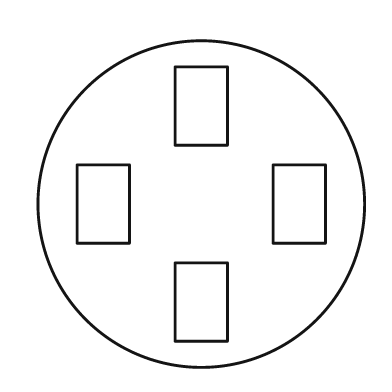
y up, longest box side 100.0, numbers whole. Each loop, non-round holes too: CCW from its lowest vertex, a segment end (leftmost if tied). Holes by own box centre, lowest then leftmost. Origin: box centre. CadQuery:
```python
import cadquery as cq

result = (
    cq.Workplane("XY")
    .moveTo(0.0, 0.0)
    .circle(50.0)
    .moveTo(-8.0, -42.0)
    .lineTo(8.0, -42.0)
    .lineTo(8.0, -18.0)
    .lineTo(-8.0, -18.0)
    .close()
    .moveTo(-38.0, -12.0)
    .lineTo(-22.0, -12.0)
    .lineTo(-22.0, 12.0)
    .lineTo(-38.0, 12.0)
    .close()
    .moveTo(22.0, -12.0)
    .lineTo(38.0, -12.0)
    .lineTo(38.0, 12.0)
    .lineTo(22.0, 12.0)
    .close()
    .moveTo(-8.0, 18.0)
    .lineTo(8.0, 18.0)
    .lineTo(8.0, 42.0)
    .lineTo(-8.0, 42.0)
    .close()
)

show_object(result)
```